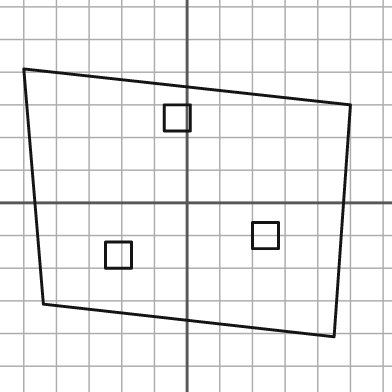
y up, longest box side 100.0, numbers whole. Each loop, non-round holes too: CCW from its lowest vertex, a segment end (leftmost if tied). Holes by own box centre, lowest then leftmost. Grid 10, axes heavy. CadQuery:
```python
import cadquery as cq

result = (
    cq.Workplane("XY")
    .moveTo(45.0, -41.0)
    .lineTo(50.0, 30.0)
    .lineTo(-50.0, 41.0)
    .lineTo(-44.0, -31.0)
    .close()
    .moveTo(-25.0, -20.0)
    .lineTo(-17.0, -20.0)
    .lineTo(-17.0, -12.0)
    .lineTo(-25.0, -12.0)
    .close()
    .moveTo(20.0, -14.0)
    .lineTo(28.0, -14.0)
    .lineTo(28.0, -6.0)
    .lineTo(20.0, -6.0)
    .close()
    .moveTo(-7.0, 22.0)
    .lineTo(1.0, 22.0)
    .lineTo(1.0, 30.0)
    .lineTo(-7.0, 30.0)
    .close()
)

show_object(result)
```